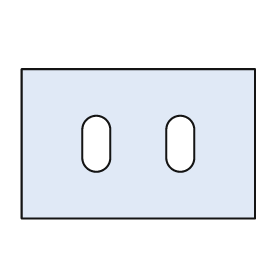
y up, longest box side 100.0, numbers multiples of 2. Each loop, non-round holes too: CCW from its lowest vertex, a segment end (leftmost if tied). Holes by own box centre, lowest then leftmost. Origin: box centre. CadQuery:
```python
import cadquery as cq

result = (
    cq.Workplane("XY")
    .moveTo(-50.0, -32.0)
    .lineTo(50.0, -32.0)
    .lineTo(50.0, 32.0)
    .lineTo(-50.0, 32.0)
    .close()
    .moveTo(-24.0, -6.0)
    .threePointArc((-18.0, -12.0), (-12.0, -6.0))
    .lineTo(-12.0, 6.0)
    .threePointArc((-18.0, 12.0), (-24.0, 6.0))
    .close()
    .moveTo(12.0, -6.0)
    .threePointArc((18.0, -12.0), (24.0, -6.0))
    .lineTo(24.0, 6.0)
    .threePointArc((18.0, 12.0), (12.0, 6.0))
    .close()
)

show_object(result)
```